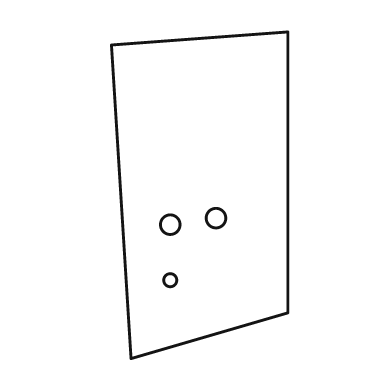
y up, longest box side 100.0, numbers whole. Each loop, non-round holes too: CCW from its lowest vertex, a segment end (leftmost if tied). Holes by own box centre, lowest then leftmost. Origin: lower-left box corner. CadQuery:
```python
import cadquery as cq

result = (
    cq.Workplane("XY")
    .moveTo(6.0, 0.0)
    .lineTo(54.0, 14.0)
    .lineTo(54.0, 100.0)
    .lineTo(0.0, 96.0)
    .close()
    .moveTo(18.0, 24.0)
    .circle(2.0)
    .moveTo(18.0, 41.0)
    .circle(3.0)
    .moveTo(32.0, 43.0)
    .circle(3.0)
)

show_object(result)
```